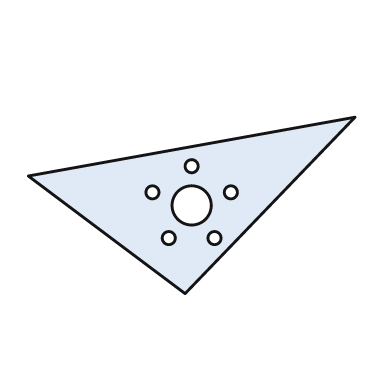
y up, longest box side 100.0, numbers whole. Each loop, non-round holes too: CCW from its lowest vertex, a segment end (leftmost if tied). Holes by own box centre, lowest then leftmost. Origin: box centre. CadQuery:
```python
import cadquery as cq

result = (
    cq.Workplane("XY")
    .moveTo(-2.0, -27.0)
    .lineTo(50.0, 27.0)
    .lineTo(-50.0, 9.0)
    .close()
    .moveTo(-7.0, -10.0)
    .circle(2.0)
    .moveTo(7.0, -10.0)
    .circle(2.0)
    .moveTo(0.0, 0.0)
    .circle(6.0)
    .moveTo(-12.0, 4.0)
    .circle(2.0)
    .moveTo(12.0, 4.0)
    .circle(2.0)
    .moveTo(0.0, 12.0)
    .circle(2.0)
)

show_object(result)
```